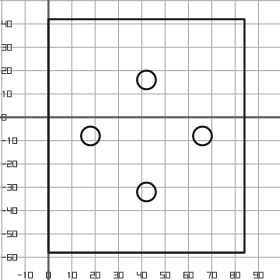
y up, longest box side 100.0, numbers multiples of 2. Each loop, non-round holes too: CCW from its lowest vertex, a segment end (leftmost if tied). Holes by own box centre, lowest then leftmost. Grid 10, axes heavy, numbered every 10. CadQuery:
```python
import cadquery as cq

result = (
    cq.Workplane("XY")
    .moveTo(0.0, -58.0)
    .lineTo(84.0, -58.0)
    .lineTo(84.0, 42.0)
    .lineTo(0.0, 42.0)
    .close()
    .moveTo(42.0, -32.0)
    .circle(4.0)
    .moveTo(18.0, -8.0)
    .circle(4.0)
    .moveTo(66.0, -8.0)
    .circle(4.0)
    .moveTo(42.0, 16.0)
    .circle(4.0)
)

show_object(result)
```